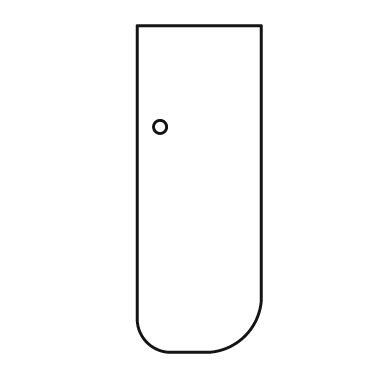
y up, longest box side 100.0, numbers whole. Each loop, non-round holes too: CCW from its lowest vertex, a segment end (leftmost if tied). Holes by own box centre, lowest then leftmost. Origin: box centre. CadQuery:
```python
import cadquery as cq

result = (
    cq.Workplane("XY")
    .moveTo(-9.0, -50.0)
    .lineTo(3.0, -50.0)
    .threePointArc((14.0, -45.0), (19.0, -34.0))
    .lineTo(19.0, 50.0)
    .lineTo(-19.0, 50.0)
    .lineTo(-19.0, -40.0)
    .threePointArc((-16.0, -47.0), (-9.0, -50.0))
    .close()
    .moveTo(-12.0, 19.0)
    .circle(2.0)
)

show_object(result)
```